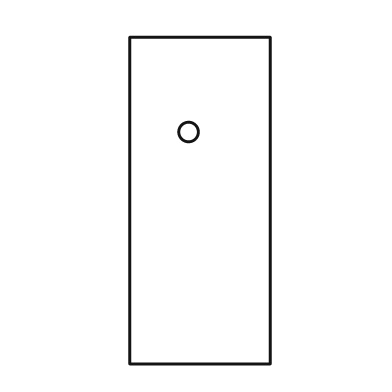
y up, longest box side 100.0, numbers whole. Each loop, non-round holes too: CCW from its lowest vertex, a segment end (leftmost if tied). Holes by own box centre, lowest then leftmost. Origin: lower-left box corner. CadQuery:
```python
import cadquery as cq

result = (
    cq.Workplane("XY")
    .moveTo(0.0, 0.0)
    .lineTo(43.0, 0.0)
    .lineTo(43.0, 100.0)
    .lineTo(0.0, 100.0)
    .close()
    .moveTo(18.0, 71.0)
    .circle(3.0)
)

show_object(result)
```